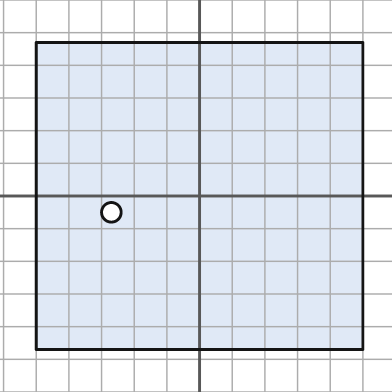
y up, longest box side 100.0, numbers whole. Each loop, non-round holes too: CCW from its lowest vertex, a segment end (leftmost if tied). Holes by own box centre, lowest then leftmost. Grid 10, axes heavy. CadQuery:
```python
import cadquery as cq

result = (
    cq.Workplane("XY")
    .moveTo(-50.0, -47.0)
    .lineTo(50.0, -47.0)
    .lineTo(50.0, 47.0)
    .lineTo(-50.0, 47.0)
    .close()
    .moveTo(-27.0, -5.0)
    .circle(3.0)
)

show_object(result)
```